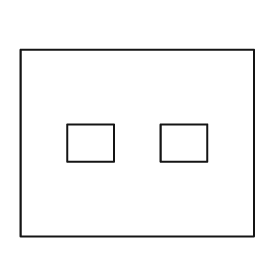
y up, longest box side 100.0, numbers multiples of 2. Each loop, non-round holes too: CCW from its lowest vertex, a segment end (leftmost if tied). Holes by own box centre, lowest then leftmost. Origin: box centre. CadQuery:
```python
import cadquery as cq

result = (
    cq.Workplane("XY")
    .moveTo(-50.0, -40.0)
    .lineTo(50.0, -40.0)
    .lineTo(50.0, 40.0)
    .lineTo(-50.0, 40.0)
    .close()
    .moveTo(-30.0, -8.0)
    .lineTo(-10.0, -8.0)
    .lineTo(-10.0, 8.0)
    .lineTo(-30.0, 8.0)
    .close()
    .moveTo(10.0, -8.0)
    .lineTo(30.0, -8.0)
    .lineTo(30.0, 8.0)
    .lineTo(10.0, 8.0)
    .close()
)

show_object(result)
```